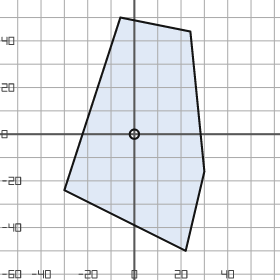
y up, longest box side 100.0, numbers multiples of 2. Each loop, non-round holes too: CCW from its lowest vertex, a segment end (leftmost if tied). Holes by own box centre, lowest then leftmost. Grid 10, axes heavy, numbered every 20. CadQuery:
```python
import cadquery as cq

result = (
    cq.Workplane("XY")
    .moveTo(22.0, -50.0)
    .lineTo(30.0, -16.0)
    .lineTo(24.0, 44.0)
    .lineTo(-6.0, 50.0)
    .lineTo(-30.0, -24.0)
    .close()
    .moveTo(0.0, 0.0)
    .circle(2.0)
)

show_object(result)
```